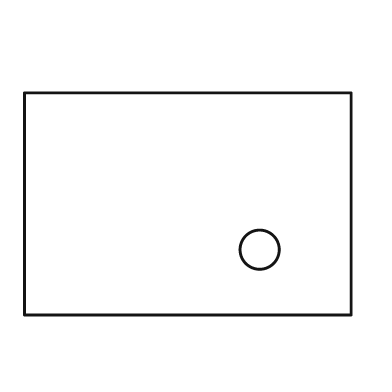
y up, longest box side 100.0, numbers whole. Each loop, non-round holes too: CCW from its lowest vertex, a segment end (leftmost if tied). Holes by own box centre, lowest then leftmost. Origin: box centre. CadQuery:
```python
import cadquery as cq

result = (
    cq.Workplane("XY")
    .moveTo(-50.0, -34.0)
    .lineTo(50.0, -34.0)
    .lineTo(50.0, 34.0)
    .lineTo(-50.0, 34.0)
    .close()
    .moveTo(22.0, -14.0)
    .circle(6.0)
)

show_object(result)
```